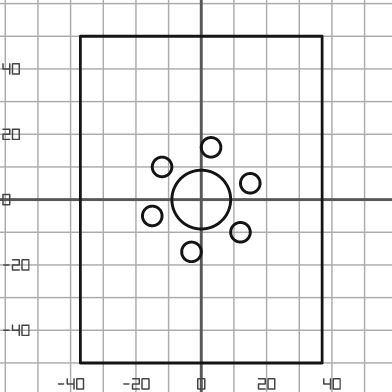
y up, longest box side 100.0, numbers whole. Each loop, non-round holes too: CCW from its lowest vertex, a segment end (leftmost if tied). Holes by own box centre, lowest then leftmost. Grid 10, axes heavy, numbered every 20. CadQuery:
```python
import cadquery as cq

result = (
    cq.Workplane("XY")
    .moveTo(-37.0, -50.0)
    .lineTo(37.0, -50.0)
    .lineTo(37.0, 50.0)
    .lineTo(-37.0, 50.0)
    .close()
    .moveTo(-3.0, -16.0)
    .circle(3.0)
    .moveTo(12.0, -10.0)
    .circle(3.0)
    .moveTo(-15.0, -5.0)
    .circle(3.0)
    .moveTo(0.0, 0.0)
    .circle(9.0)
    .moveTo(15.0, 5.0)
    .circle(3.0)
    .moveTo(-12.0, 10.0)
    .circle(3.0)
    .moveTo(3.0, 16.0)
    .circle(3.0)
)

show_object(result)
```